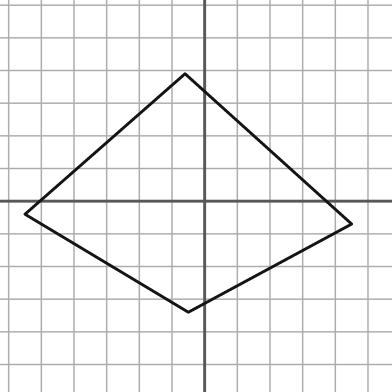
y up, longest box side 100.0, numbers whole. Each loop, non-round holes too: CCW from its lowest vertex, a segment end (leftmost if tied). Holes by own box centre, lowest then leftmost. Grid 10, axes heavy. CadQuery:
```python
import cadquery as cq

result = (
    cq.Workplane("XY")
    .moveTo(-5.0, -34.0)
    .lineTo(45.0, -7.0)
    .lineTo(-6.0, 39.0)
    .lineTo(-55.0, -4.0)
    .close()
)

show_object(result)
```